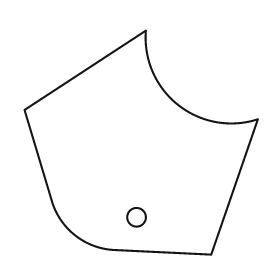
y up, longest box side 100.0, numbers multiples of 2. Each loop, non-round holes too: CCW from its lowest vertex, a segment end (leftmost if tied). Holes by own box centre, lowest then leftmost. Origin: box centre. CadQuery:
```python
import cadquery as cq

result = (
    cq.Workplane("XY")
    .moveTo(30.0, -48.0)
    .lineTo(50.0, 10.0)
    .threePointArc((16.0, 16.0), (2.0, 48.0))
    .lineTo(-50.0, 14.0)
    .lineTo(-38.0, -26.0)
    .threePointArc((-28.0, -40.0), (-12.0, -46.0))
    .close()
    .moveTo(-2.0, -32.0)
    .circle(4.0)
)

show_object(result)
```